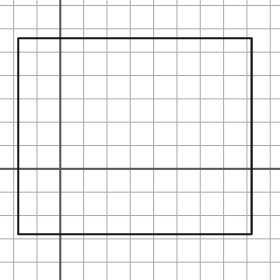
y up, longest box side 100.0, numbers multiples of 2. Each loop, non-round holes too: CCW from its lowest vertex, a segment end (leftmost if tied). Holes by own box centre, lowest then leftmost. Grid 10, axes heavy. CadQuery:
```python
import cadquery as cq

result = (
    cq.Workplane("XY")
    .moveTo(-18.0, -28.0)
    .lineTo(82.0, -28.0)
    .lineTo(82.0, 56.0)
    .lineTo(-18.0, 56.0)
    .close()
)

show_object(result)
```